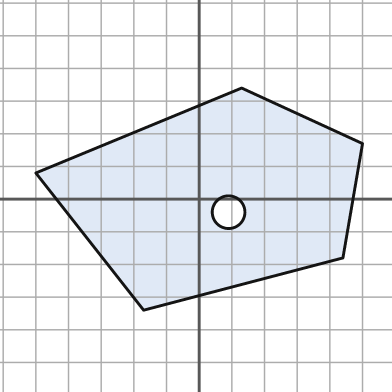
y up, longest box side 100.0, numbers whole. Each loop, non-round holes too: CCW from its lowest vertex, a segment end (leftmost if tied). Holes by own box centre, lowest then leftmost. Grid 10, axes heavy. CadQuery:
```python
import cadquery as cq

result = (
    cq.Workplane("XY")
    .moveTo(-17.0, -34.0)
    .lineTo(44.0, -18.0)
    .lineTo(50.0, 17.0)
    .lineTo(13.0, 34.0)
    .lineTo(-50.0, 8.0)
    .close()
    .moveTo(9.0, -4.0)
    .circle(5.0)
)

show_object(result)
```